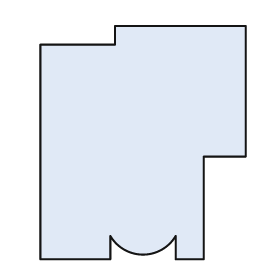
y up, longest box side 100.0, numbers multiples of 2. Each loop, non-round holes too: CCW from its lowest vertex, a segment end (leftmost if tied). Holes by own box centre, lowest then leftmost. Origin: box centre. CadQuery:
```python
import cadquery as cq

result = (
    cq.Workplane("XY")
    .moveTo(-44.0, -50.0)
    .lineTo(-14.0, -50.0)
    .lineTo(-14.0, -40.0)
    .threePointArc((0.0, -48.0), (14.0, -40.0))
    .lineTo(14.0, -50.0)
    .lineTo(26.0, -50.0)
    .lineTo(26.0, -6.0)
    .lineTo(44.0, -6.0)
    .lineTo(44.0, 50.0)
    .lineTo(-12.0, 50.0)
    .lineTo(-12.0, 42.0)
    .lineTo(-44.0, 42.0)
    .close()
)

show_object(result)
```